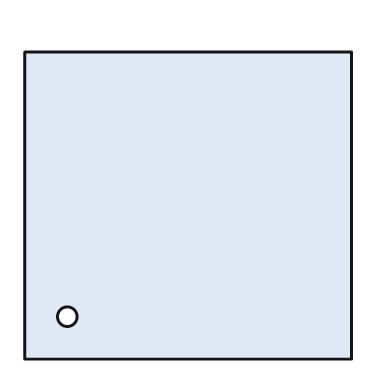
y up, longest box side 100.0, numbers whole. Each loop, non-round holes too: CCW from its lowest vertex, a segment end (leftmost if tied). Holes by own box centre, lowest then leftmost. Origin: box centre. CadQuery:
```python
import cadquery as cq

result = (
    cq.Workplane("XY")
    .moveTo(-50.0, -47.0)
    .lineTo(50.0, -47.0)
    .lineTo(50.0, 47.0)
    .lineTo(-50.0, 47.0)
    .close()
    .moveTo(-37.0, -34.0)
    .circle(3.0)
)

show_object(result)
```